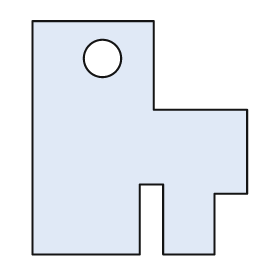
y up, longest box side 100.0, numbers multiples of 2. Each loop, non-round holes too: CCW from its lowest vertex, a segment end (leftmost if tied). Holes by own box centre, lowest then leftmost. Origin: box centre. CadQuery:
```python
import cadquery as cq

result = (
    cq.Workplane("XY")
    .moveTo(-46.0, -50.0)
    .lineTo(0.0, -50.0)
    .lineTo(0.0, -20.0)
    .lineTo(10.0, -20.0)
    .lineTo(10.0, -50.0)
    .lineTo(32.0, -50.0)
    .lineTo(32.0, -24.0)
    .lineTo(46.0, -24.0)
    .lineTo(46.0, 12.0)
    .lineTo(6.0, 12.0)
    .lineTo(6.0, 50.0)
    .lineTo(-46.0, 50.0)
    .close()
    .moveTo(-16.0, 34.0)
    .circle(8.0)
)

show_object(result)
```